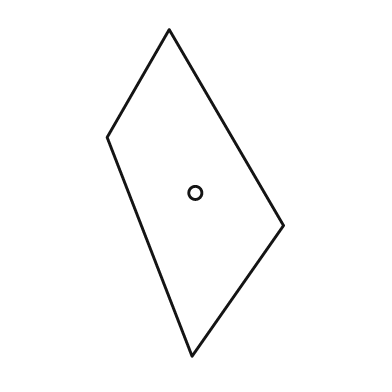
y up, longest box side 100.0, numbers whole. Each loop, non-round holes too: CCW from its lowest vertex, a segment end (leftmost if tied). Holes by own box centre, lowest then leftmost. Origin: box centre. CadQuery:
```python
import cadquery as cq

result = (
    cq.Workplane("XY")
    .moveTo(-1.0, -50.0)
    .lineTo(27.0, -10.0)
    .lineTo(-8.0, 50.0)
    .lineTo(-27.0, 17.0)
    .close()
    .moveTo(0.0, 0.0)
    .circle(2.0)
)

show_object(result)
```